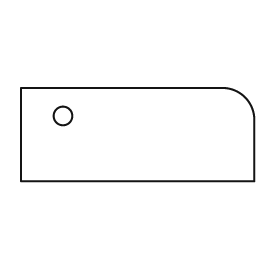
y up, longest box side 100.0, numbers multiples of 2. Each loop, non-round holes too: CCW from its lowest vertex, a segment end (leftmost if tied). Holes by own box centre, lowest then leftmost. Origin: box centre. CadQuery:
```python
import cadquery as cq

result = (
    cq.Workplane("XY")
    .moveTo(-50.0, -20.0)
    .lineTo(50.0, -20.0)
    .lineTo(50.0, 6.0)
    .threePointArc((46.0, 16.0), (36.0, 20.0))
    .lineTo(-50.0, 20.0)
    .close()
    .moveTo(-32.0, 8.0)
    .circle(4.0)
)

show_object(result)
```